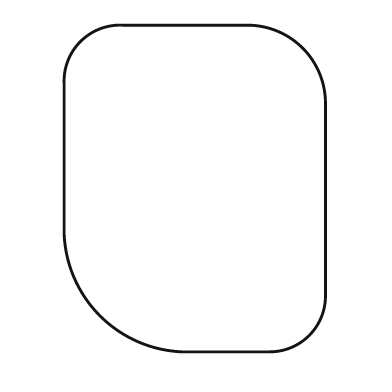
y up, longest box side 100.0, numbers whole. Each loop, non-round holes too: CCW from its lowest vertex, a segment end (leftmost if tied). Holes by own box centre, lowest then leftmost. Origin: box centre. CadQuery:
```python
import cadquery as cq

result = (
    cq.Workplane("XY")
    .moveTo(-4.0, -50.0)
    .lineTo(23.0, -50.0)
    .threePointArc((35.0, -45.0), (40.0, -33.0))
    .lineTo(40.0, 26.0)
    .threePointArc((33.0, 43.0), (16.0, 50.0))
    .lineTo(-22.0, 50.0)
    .threePointArc((-35.0, 45.0), (-40.0, 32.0))
    .lineTo(-40.0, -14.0)
    .threePointArc((-29.0, -39.0), (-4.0, -50.0))
    .close()
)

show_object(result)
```